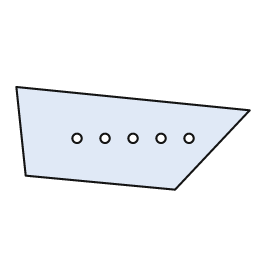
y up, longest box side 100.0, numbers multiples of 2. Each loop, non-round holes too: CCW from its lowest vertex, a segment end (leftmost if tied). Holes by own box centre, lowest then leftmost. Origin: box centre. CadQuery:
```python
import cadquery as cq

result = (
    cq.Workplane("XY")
    .moveTo(18.0, -22.0)
    .lineTo(50.0, 12.0)
    .lineTo(-50.0, 22.0)
    .lineTo(-46.0, -16.0)
    .close()
    .moveTo(-24.0, 0.0)
    .circle(2.0)
    .moveTo(-12.0, 0.0)
    .circle(2.0)
    .moveTo(0.0, 0.0)
    .circle(2.0)
    .moveTo(12.0, 0.0)
    .circle(2.0)
    .moveTo(24.0, 0.0)
    .circle(2.0)
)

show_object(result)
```